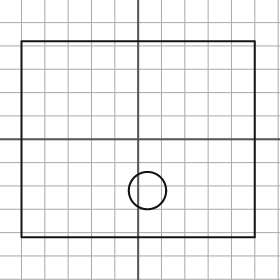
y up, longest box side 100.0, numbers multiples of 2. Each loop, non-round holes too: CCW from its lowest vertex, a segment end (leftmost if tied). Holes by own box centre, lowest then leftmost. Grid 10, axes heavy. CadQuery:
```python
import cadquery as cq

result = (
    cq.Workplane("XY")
    .moveTo(-50.0, -42.0)
    .lineTo(50.0, -42.0)
    .lineTo(50.0, 42.0)
    .lineTo(-50.0, 42.0)
    .close()
    .moveTo(4.0, -22.0)
    .circle(8.0)
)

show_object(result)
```